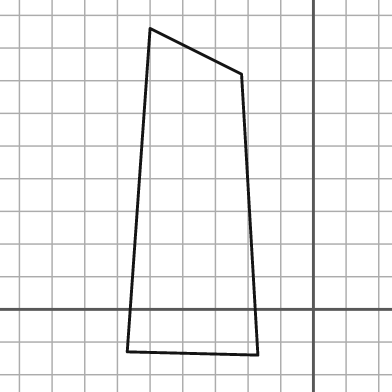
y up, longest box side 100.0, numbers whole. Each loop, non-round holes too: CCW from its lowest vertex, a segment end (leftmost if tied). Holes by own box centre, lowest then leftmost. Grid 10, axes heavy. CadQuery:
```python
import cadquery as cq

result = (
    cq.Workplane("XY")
    .moveTo(-17.0, -14.0)
    .lineTo(-22.0, 72.0)
    .lineTo(-50.0, 86.0)
    .lineTo(-57.0, -13.0)
    .close()
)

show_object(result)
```